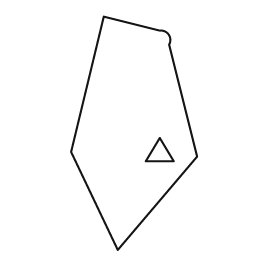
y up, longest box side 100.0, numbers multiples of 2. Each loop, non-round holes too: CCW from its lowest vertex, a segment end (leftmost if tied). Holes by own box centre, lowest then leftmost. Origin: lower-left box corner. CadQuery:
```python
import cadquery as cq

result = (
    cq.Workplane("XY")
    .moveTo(20.0, 0.0)
    .lineTo(54.0, 40.0)
    .lineTo(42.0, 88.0)
    .threePointArc((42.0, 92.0), (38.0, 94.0))
    .lineTo(14.0, 100.0)
    .lineTo(0.0, 42.0)
    .close()
    .moveTo(32.0, 38.0)
    .lineTo(44.0, 38.0)
    .lineTo(38.0, 48.0)
    .close()
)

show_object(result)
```